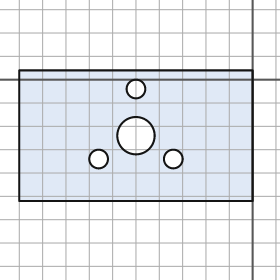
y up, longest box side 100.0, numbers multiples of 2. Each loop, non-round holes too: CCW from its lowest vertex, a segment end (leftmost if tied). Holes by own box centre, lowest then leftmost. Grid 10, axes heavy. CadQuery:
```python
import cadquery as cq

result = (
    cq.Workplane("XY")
    .moveTo(-100.0, -52.0)
    .lineTo(0.0, -52.0)
    .lineTo(0.0, 4.0)
    .lineTo(-100.0, 4.0)
    .close()
    .moveTo(-66.0, -34.0)
    .circle(4.0)
    .moveTo(-34.0, -34.0)
    .circle(4.0)
    .moveTo(-50.0, -24.0)
    .circle(8.0)
    .moveTo(-50.0, -4.0)
    .circle(4.0)
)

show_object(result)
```